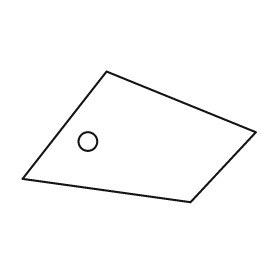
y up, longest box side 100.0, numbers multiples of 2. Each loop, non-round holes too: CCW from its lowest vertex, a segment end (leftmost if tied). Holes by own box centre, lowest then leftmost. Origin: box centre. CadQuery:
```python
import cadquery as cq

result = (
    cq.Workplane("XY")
    .moveTo(22.0, -28.0)
    .lineTo(50.0, 2.0)
    .lineTo(-14.0, 28.0)
    .lineTo(-50.0, -18.0)
    .close()
    .moveTo(-22.0, -2.0)
    .circle(4.0)
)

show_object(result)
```